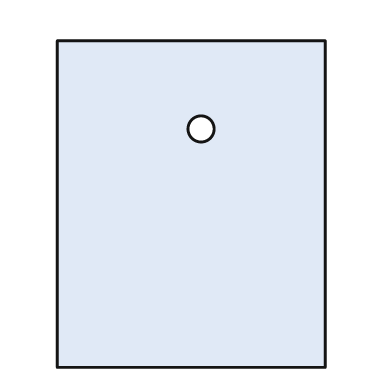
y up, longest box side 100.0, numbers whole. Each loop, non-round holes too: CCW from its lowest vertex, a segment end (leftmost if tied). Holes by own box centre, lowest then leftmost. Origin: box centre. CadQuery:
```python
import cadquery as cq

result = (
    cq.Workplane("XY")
    .moveTo(-41.0, -50.0)
    .lineTo(41.0, -50.0)
    .lineTo(41.0, 50.0)
    .lineTo(-41.0, 50.0)
    .close()
    .moveTo(3.0, 23.0)
    .circle(4.0)
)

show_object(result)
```